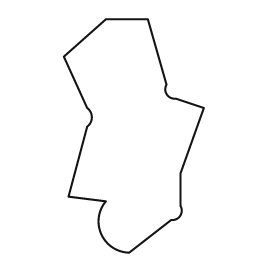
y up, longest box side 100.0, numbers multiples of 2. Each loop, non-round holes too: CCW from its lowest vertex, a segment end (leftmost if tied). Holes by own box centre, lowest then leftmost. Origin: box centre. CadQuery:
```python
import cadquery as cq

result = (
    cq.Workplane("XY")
    .moveTo(-2.0, -50.0)
    .lineTo(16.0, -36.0)
    .threePointArc((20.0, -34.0), (20.0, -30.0))
    .lineTo(20.0, -16.0)
    .lineTo(30.0, 12.0)
    .lineTo(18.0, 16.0)
    .threePointArc((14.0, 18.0), (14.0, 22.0))
    .lineTo(6.0, 50.0)
    .lineTo(-12.0, 50.0)
    .lineTo(-30.0, 34.0)
    .lineTo(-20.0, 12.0)
    .threePointArc((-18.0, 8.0), (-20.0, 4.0))
    .lineTo(-28.0, -26.0)
    .lineTo(-12.0, -28.0)
    .threePointArc((-14.0, -42.0), (-2.0, -50.0))
    .close()
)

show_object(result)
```